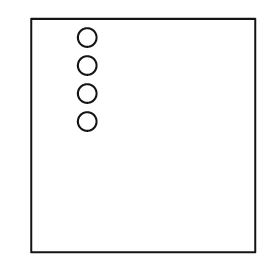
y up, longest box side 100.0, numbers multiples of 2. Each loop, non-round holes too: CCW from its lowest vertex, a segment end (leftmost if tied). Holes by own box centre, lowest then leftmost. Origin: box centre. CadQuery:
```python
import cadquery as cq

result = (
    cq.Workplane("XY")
    .moveTo(-48.0, -50.0)
    .lineTo(48.0, -50.0)
    .lineTo(48.0, 50.0)
    .lineTo(-48.0, 50.0)
    .close()
    .moveTo(-24.0, 6.0)
    .circle(4.0)
    .moveTo(-24.0, 18.0)
    .circle(4.0)
    .moveTo(-24.0, 30.0)
    .circle(4.0)
    .moveTo(-24.0, 42.0)
    .circle(4.0)
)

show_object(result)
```